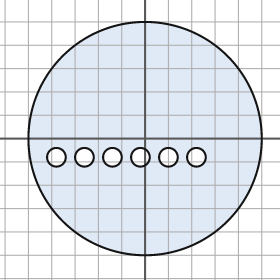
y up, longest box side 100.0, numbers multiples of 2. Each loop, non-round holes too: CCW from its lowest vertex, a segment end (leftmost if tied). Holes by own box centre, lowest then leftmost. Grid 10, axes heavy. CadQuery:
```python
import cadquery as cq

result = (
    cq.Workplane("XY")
    .moveTo(0.0, 0.0)
    .circle(50.0)
    .moveTo(-38.0, -8.0)
    .circle(4.0)
    .moveTo(-26.0, -8.0)
    .circle(4.0)
    .moveTo(-14.0, -8.0)
    .circle(4.0)
    .moveTo(-2.0, -8.0)
    .circle(4.0)
    .moveTo(10.0, -8.0)
    .circle(4.0)
    .moveTo(22.0, -8.0)
    .circle(4.0)
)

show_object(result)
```